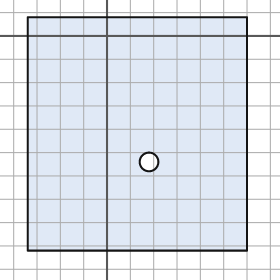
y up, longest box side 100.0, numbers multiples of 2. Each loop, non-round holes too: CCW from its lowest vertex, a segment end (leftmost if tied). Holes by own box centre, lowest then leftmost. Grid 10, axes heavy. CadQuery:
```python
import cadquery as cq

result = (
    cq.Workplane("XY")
    .moveTo(-34.0, -92.0)
    .lineTo(60.0, -92.0)
    .lineTo(60.0, 8.0)
    .lineTo(-34.0, 8.0)
    .close()
    .moveTo(18.0, -54.0)
    .circle(4.0)
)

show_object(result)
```